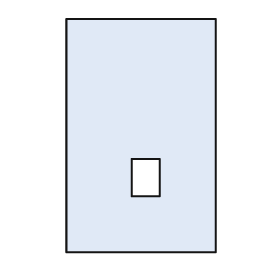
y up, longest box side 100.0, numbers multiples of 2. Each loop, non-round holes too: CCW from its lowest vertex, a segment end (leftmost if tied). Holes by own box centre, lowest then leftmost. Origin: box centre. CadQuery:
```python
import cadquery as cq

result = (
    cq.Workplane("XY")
    .moveTo(-32.0, -50.0)
    .lineTo(32.0, -50.0)
    .lineTo(32.0, 50.0)
    .lineTo(-32.0, 50.0)
    .close()
    .moveTo(-4.0, -26.0)
    .lineTo(8.0, -26.0)
    .lineTo(8.0, -10.0)
    .lineTo(-4.0, -10.0)
    .close()
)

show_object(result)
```